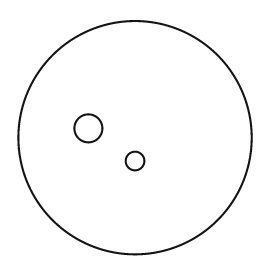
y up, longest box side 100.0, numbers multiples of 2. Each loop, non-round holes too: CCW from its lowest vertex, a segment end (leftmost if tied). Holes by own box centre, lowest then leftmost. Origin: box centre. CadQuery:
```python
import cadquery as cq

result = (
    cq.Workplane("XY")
    .moveTo(0.0, 0.0)
    .circle(50.0)
    .moveTo(0.0, -10.0)
    .circle(4.0)
    .moveTo(-20.0, 4.0)
    .circle(6.0)
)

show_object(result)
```